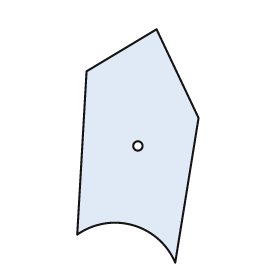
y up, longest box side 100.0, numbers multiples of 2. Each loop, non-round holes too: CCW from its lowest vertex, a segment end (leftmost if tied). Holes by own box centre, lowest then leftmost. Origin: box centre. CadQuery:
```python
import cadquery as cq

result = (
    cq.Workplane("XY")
    .moveTo(16.0, -50.0)
    .lineTo(26.0, 12.0)
    .lineTo(8.0, 50.0)
    .lineTo(-22.0, 32.0)
    .lineTo(-26.0, -38.0)
    .threePointArc((-2.0, -34.0), (16.0, -50.0))
    .close()
    .moveTo(0.0, 0.0)
    .circle(2.0)
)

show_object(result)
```